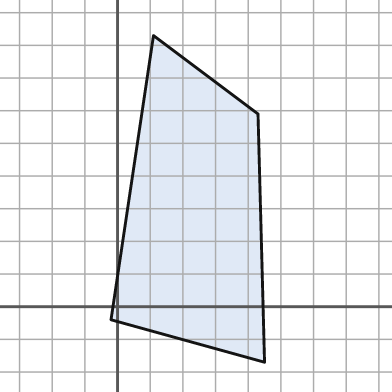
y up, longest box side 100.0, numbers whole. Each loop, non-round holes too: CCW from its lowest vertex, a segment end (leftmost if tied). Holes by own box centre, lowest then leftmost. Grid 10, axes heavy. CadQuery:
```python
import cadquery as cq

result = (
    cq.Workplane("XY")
    .moveTo(45.0, -17.0)
    .lineTo(43.0, 59.0)
    .lineTo(11.0, 83.0)
    .lineTo(-2.0, -4.0)
    .close()
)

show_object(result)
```